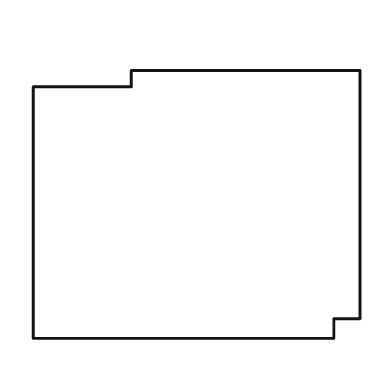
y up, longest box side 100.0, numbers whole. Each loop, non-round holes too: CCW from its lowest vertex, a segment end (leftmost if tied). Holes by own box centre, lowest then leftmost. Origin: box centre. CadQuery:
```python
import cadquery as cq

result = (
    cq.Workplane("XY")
    .moveTo(-50.0, -41.0)
    .lineTo(42.0, -41.0)
    .lineTo(42.0, -35.0)
    .lineTo(50.0, -35.0)
    .lineTo(50.0, 41.0)
    .lineTo(-20.0, 41.0)
    .lineTo(-20.0, 36.0)
    .lineTo(-50.0, 36.0)
    .close()
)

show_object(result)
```